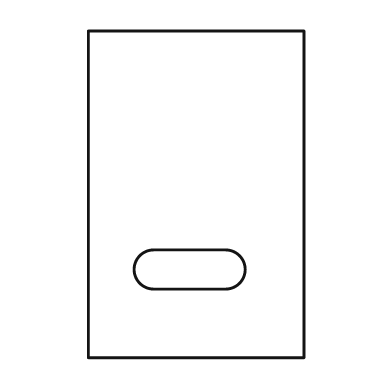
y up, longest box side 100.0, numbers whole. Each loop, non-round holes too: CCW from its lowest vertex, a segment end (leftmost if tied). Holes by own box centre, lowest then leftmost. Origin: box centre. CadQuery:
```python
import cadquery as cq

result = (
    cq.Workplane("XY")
    .moveTo(-33.0, -50.0)
    .lineTo(33.0, -50.0)
    .lineTo(33.0, 50.0)
    .lineTo(-33.0, 50.0)
    .close()
    .moveTo(-13.0, -29.0)
    .lineTo(9.0, -29.0)
    .threePointArc((15.0, -23.0), (9.0, -17.0))
    .lineTo(-13.0, -17.0)
    .threePointArc((-19.0, -23.0), (-13.0, -29.0))
    .close()
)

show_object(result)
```